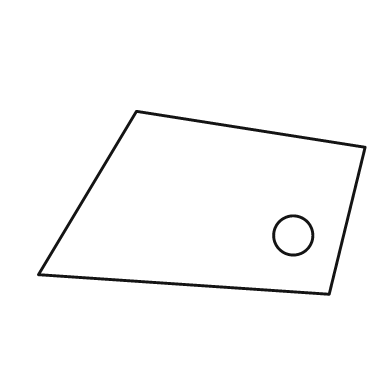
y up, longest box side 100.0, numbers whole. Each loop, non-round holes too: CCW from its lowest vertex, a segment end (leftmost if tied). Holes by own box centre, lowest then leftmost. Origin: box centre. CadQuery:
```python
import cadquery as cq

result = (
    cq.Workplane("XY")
    .moveTo(39.0, -28.0)
    .lineTo(50.0, 17.0)
    .lineTo(-20.0, 28.0)
    .lineTo(-50.0, -22.0)
    .close()
    .moveTo(28.0, -10.0)
    .circle(6.0)
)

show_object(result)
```